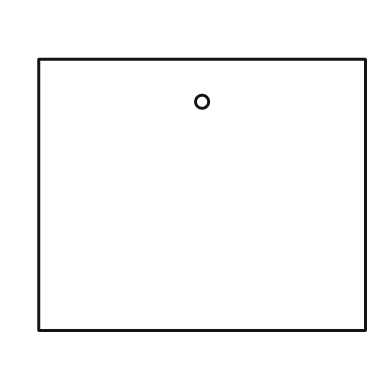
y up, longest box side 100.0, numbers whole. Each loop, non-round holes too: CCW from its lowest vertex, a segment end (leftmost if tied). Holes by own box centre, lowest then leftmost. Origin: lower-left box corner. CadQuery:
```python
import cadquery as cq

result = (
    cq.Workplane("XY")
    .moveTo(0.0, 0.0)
    .lineTo(100.0, 0.0)
    .lineTo(100.0, 83.0)
    .lineTo(0.0, 83.0)
    .close()
    .moveTo(50.0, 70.0)
    .circle(2.0)
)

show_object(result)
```